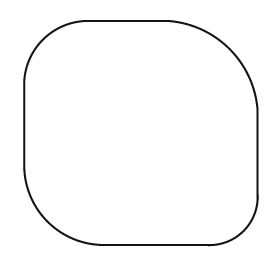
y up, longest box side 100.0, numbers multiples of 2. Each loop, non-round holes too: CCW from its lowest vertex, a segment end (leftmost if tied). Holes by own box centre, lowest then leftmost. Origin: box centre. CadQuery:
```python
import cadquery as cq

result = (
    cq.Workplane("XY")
    .moveTo(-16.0, -48.0)
    .lineTo(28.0, -48.0)
    .threePointArc((44.0, -42.0), (50.0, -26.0))
    .lineTo(50.0, 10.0)
    .threePointArc((38.0, 36.0), (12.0, 48.0))
    .lineTo(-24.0, 48.0)
    .threePointArc((-42.0, 40.0), (-50.0, 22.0))
    .lineTo(-50.0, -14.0)
    .threePointArc((-40.0, -38.0), (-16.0, -48.0))
    .close()
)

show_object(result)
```